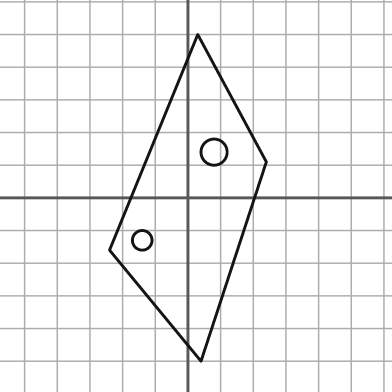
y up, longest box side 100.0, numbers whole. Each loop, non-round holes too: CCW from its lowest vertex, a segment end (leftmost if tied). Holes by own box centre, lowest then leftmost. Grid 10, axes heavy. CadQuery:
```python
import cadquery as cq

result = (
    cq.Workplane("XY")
    .moveTo(4.0, -50.0)
    .lineTo(24.0, 11.0)
    .lineTo(3.0, 50.0)
    .lineTo(-24.0, -16.0)
    .close()
    .moveTo(-14.0, -13.0)
    .circle(3.0)
    .moveTo(8.0, 14.0)
    .circle(4.0)
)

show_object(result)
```